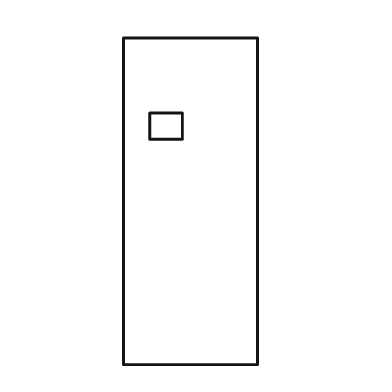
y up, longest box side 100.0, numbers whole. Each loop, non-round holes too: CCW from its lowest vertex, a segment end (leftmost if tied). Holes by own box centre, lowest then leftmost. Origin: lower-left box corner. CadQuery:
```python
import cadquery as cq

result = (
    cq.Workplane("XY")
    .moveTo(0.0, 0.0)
    .lineTo(41.0, 0.0)
    .lineTo(41.0, 100.0)
    .lineTo(0.0, 100.0)
    .close()
    .moveTo(8.0, 69.0)
    .lineTo(18.0, 69.0)
    .lineTo(18.0, 77.0)
    .lineTo(8.0, 77.0)
    .close()
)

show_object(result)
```